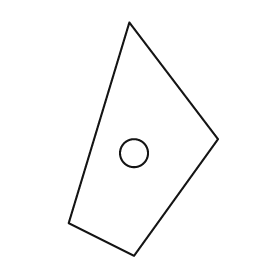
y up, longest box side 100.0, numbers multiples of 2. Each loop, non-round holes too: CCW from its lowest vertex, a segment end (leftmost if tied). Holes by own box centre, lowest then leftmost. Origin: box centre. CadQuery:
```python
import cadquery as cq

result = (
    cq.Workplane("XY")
    .moveTo(-4.0, -50.0)
    .lineTo(32.0, 0.0)
    .lineTo(-6.0, 50.0)
    .lineTo(-32.0, -36.0)
    .close()
    .moveTo(-4.0, -6.0)
    .circle(6.0)
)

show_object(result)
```